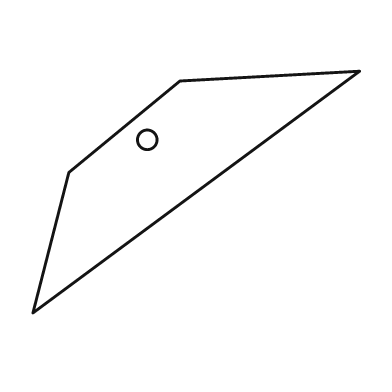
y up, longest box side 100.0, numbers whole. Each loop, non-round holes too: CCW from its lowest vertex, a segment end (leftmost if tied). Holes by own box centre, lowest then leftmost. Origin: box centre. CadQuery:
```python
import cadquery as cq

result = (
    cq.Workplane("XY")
    .moveTo(-50.0, -37.0)
    .lineTo(50.0, 37.0)
    .lineTo(-5.0, 34.0)
    .lineTo(-39.0, 6.0)
    .close()
    .moveTo(-15.0, 16.0)
    .circle(3.0)
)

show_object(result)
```